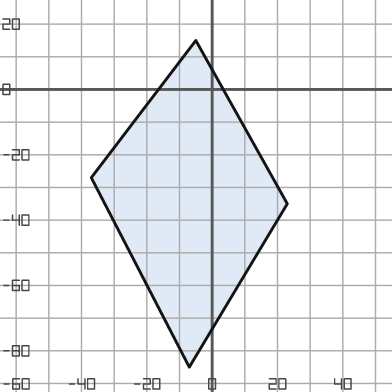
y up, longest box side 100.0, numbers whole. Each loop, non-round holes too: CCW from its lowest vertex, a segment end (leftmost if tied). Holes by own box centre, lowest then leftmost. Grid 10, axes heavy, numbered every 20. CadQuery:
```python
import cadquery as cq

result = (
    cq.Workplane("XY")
    .moveTo(-7.0, -85.0)
    .lineTo(23.0, -35.0)
    .lineTo(-5.0, 15.0)
    .lineTo(-37.0, -27.0)
    .close()
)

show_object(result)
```